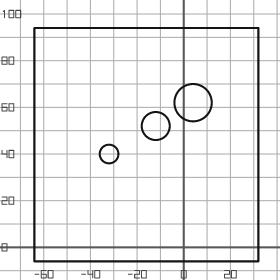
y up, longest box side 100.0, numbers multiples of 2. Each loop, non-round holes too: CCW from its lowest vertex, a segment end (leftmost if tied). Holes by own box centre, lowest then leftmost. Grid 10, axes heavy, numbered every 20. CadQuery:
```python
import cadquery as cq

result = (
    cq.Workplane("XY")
    .moveTo(-64.0, -6.0)
    .lineTo(32.0, -6.0)
    .lineTo(32.0, 94.0)
    .lineTo(-64.0, 94.0)
    .close()
    .moveTo(-32.0, 40.0)
    .circle(4.0)
    .moveTo(-12.0, 52.0)
    .circle(6.0)
    .moveTo(4.0, 62.0)
    .circle(8.0)
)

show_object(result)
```